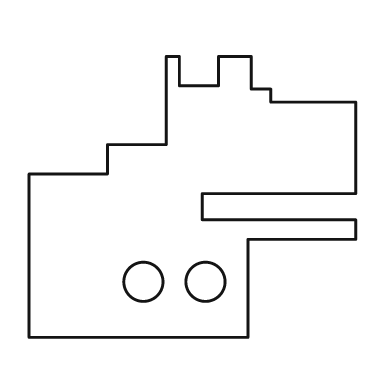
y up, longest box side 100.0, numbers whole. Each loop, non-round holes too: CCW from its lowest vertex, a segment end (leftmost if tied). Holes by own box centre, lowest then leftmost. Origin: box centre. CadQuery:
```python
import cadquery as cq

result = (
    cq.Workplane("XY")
    .moveTo(-50.0, -43.0)
    .lineTo(17.0, -43.0)
    .lineTo(17.0, -13.0)
    .lineTo(50.0, -13.0)
    .lineTo(50.0, -7.0)
    .lineTo(3.0, -7.0)
    .lineTo(3.0, 1.0)
    .lineTo(50.0, 1.0)
    .lineTo(50.0, 29.0)
    .lineTo(24.0, 29.0)
    .lineTo(24.0, 33.0)
    .lineTo(18.0, 33.0)
    .lineTo(18.0, 43.0)
    .lineTo(8.0, 43.0)
    .lineTo(8.0, 34.0)
    .lineTo(-4.0, 34.0)
    .lineTo(-4.0, 43.0)
    .lineTo(-8.0, 43.0)
    .lineTo(-8.0, 16.0)
    .lineTo(-26.0, 16.0)
    .lineTo(-26.0, 7.0)
    .lineTo(-50.0, 7.0)
    .close()
    .moveTo(-15.0, -26.0)
    .circle(6.0)
    .moveTo(4.0, -26.0)
    .circle(6.0)
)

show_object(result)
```